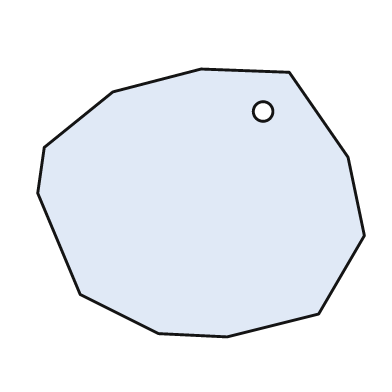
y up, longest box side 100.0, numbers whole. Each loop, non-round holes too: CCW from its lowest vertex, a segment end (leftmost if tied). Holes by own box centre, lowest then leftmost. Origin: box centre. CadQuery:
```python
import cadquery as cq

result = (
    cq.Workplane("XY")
    .moveTo(8.0, -41.0)
    .lineTo(36.0, -34.0)
    .lineTo(50.0, -10.0)
    .lineTo(45.0, 14.0)
    .lineTo(27.0, 40.0)
    .lineTo(0.0, 41.0)
    .lineTo(-27.0, 34.0)
    .lineTo(-48.0, 17.0)
    .lineTo(-50.0, 3.0)
    .lineTo(-37.0, -28.0)
    .lineTo(-13.0, -40.0)
    .close()
    .moveTo(19.0, 28.0)
    .circle(3.0)
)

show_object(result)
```